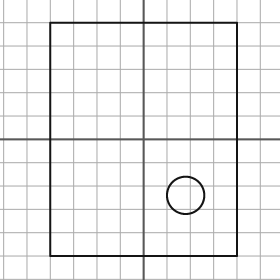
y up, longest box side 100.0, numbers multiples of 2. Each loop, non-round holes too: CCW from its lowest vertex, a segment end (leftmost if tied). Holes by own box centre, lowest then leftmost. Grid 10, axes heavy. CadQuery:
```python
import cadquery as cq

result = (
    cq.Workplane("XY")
    .moveTo(-40.0, -50.0)
    .lineTo(40.0, -50.0)
    .lineTo(40.0, 50.0)
    .lineTo(-40.0, 50.0)
    .close()
    .moveTo(18.0, -24.0)
    .circle(8.0)
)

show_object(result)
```